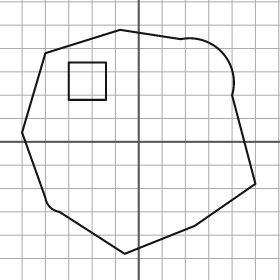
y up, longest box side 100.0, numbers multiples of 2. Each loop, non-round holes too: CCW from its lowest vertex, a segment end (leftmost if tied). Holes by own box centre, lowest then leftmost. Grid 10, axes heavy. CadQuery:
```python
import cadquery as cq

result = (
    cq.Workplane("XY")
    .moveTo(-6.0, -48.0)
    .lineTo(24.0, -36.0)
    .lineTo(50.0, -18.0)
    .lineTo(40.0, 20.0)
    .threePointArc((36.0, 38.0), (18.0, 44.0))
    .lineTo(-8.0, 48.0)
    .lineTo(-40.0, 38.0)
    .lineTo(-50.0, 4.0)
    .lineTo(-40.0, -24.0)
    .threePointArc((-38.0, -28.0), (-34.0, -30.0))
    .close()
    .moveTo(-30.0, 18.0)
    .lineTo(-14.0, 18.0)
    .lineTo(-14.0, 34.0)
    .lineTo(-30.0, 34.0)
    .close()
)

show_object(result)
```